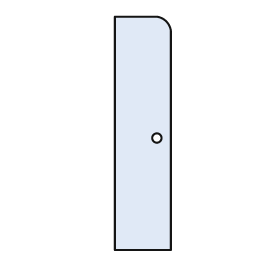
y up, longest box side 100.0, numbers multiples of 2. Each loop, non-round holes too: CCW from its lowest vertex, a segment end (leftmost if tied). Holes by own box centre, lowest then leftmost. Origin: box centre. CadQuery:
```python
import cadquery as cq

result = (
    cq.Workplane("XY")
    .moveTo(-12.0, -50.0)
    .lineTo(12.0, -50.0)
    .lineTo(12.0, 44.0)
    .threePointArc((10.0, 48.0), (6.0, 50.0))
    .lineTo(-12.0, 50.0)
    .close()
    .moveTo(6.0, -2.0)
    .circle(2.0)
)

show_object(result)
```